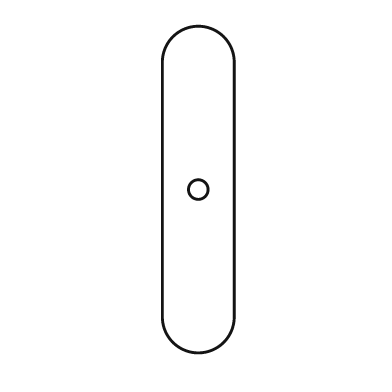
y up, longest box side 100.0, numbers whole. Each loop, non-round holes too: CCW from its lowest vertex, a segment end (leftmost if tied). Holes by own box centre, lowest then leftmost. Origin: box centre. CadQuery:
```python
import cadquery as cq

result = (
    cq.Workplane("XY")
    .moveTo(-11.0, -39.0)
    .threePointArc((0.0, -50.0), (11.0, -39.0))
    .lineTo(11.0, 39.0)
    .threePointArc((0.0, 50.0), (-11.0, 39.0))
    .close()
    .moveTo(0.0, 0.0)
    .circle(3.0)
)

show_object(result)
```